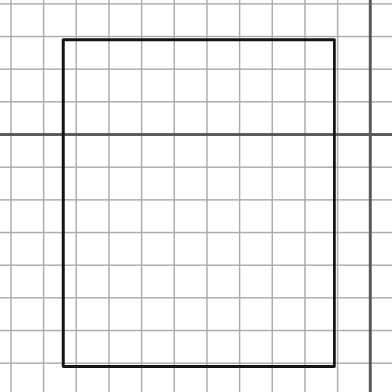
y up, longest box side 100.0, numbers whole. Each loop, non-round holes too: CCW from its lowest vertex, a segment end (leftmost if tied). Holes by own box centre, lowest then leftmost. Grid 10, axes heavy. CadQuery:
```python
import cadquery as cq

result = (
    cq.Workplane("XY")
    .moveTo(-94.0, -71.0)
    .lineTo(-11.0, -71.0)
    .lineTo(-11.0, 29.0)
    .lineTo(-94.0, 29.0)
    .close()
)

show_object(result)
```